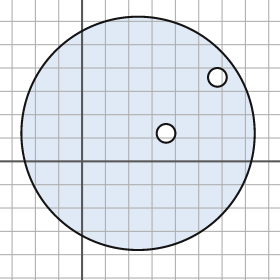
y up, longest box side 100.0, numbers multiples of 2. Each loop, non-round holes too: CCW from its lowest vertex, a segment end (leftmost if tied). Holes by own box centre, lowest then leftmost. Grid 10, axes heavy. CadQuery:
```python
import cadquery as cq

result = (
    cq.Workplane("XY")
    .moveTo(24.0, 12.0)
    .circle(50.0)
    .moveTo(36.0, 12.0)
    .circle(4.0)
    .moveTo(58.0, 36.0)
    .circle(4.0)
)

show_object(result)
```